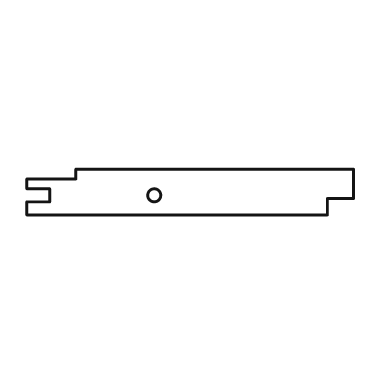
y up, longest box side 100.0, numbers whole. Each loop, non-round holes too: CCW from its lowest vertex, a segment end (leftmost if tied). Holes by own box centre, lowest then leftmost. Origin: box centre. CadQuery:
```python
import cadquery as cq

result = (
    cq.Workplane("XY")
    .moveTo(-50.0, -7.0)
    .lineTo(42.0, -7.0)
    .lineTo(42.0, -2.0)
    .lineTo(50.0, -2.0)
    .lineTo(50.0, 7.0)
    .lineTo(-35.0, 7.0)
    .lineTo(-35.0, 4.0)
    .lineTo(-50.0, 4.0)
    .lineTo(-50.0, 1.0)
    .lineTo(-43.0, 1.0)
    .lineTo(-43.0, -3.0)
    .lineTo(-50.0, -3.0)
    .close()
    .moveTo(-11.0, -1.0)
    .circle(2.0)
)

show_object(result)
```